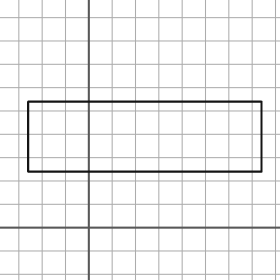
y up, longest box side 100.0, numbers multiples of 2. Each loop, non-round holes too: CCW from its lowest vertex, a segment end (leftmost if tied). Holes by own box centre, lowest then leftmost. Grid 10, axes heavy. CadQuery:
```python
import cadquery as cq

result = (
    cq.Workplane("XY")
    .moveTo(-26.0, 24.0)
    .lineTo(74.0, 24.0)
    .lineTo(74.0, 54.0)
    .lineTo(-26.0, 54.0)
    .close()
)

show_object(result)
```